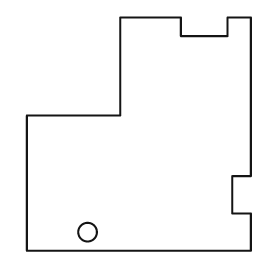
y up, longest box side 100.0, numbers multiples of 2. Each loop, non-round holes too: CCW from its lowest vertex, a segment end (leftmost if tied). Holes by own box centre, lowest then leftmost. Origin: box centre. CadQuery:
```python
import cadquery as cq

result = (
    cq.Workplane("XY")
    .moveTo(-48.0, -50.0)
    .lineTo(48.0, -50.0)
    .lineTo(48.0, -34.0)
    .lineTo(40.0, -34.0)
    .lineTo(40.0, -18.0)
    .lineTo(48.0, -18.0)
    .lineTo(48.0, 50.0)
    .lineTo(38.0, 50.0)
    .lineTo(38.0, 42.0)
    .lineTo(18.0, 42.0)
    .lineTo(18.0, 50.0)
    .lineTo(-8.0, 50.0)
    .lineTo(-8.0, 8.0)
    .lineTo(-48.0, 8.0)
    .close()
    .moveTo(-22.0, -42.0)
    .circle(4.0)
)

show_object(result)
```